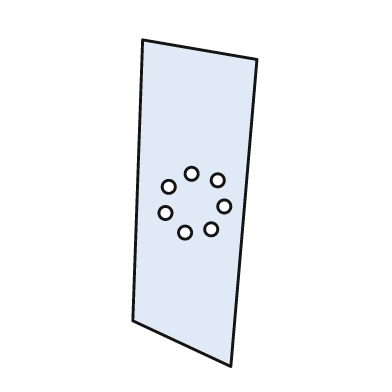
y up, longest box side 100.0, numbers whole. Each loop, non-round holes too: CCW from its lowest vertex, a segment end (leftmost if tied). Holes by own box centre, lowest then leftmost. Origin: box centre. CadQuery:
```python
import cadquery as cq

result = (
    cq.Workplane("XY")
    .moveTo(11.0, -50.0)
    .lineTo(19.0, 44.0)
    .lineTo(-16.0, 50.0)
    .lineTo(-19.0, -36.0)
    .close()
    .moveTo(-3.0, -9.0)
    .circle(2.0)
    .moveTo(5.0, -8.0)
    .circle(2.0)
    .moveTo(-9.0, -3.0)
    .circle(2.0)
    .moveTo(9.0, -1.0)
    .circle(2.0)
    .moveTo(-8.0, 5.0)
    .circle(2.0)
    .moveTo(7.0, 7.0)
    .circle(2.0)
    .moveTo(-1.0, 9.0)
    .circle(2.0)
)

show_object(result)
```